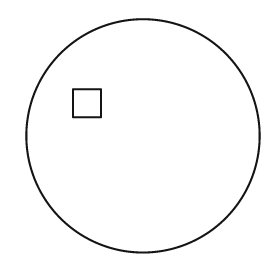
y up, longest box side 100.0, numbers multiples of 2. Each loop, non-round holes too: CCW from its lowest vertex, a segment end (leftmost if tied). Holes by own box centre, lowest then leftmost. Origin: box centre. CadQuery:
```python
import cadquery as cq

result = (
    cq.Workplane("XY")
    .moveTo(0.0, 0.0)
    .circle(50.0)
    .moveTo(-30.0, 8.0)
    .lineTo(-18.0, 8.0)
    .lineTo(-18.0, 20.0)
    .lineTo(-30.0, 20.0)
    .close()
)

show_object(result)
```